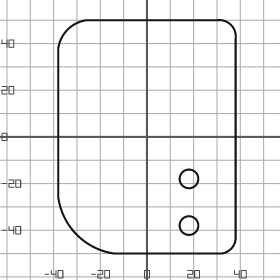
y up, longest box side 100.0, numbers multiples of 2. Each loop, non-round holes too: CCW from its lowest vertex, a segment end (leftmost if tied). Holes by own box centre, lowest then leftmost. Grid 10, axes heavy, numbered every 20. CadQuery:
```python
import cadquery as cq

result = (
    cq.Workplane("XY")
    .moveTo(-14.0, -50.0)
    .lineTo(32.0, -50.0)
    .threePointArc((36.0, -48.0), (38.0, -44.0))
    .lineTo(38.0, 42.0)
    .threePointArc((36.0, 48.0), (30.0, 50.0))
    .lineTo(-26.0, 50.0)
    .threePointArc((-34.0, 46.0), (-38.0, 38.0))
    .lineTo(-38.0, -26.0)
    .threePointArc((-30.0, -42.0), (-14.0, -50.0))
    .close()
    .moveTo(18.0, -38.0)
    .circle(4.0)
    .moveTo(18.0, -18.0)
    .circle(4.0)
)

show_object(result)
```